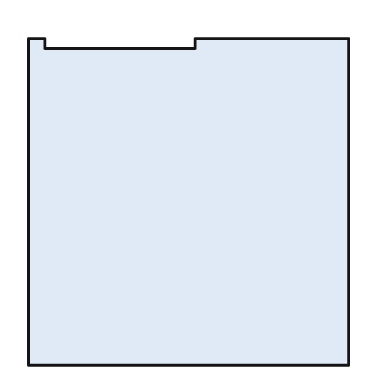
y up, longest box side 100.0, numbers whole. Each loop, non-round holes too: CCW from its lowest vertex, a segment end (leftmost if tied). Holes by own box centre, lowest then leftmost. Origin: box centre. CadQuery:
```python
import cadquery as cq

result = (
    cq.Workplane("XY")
    .moveTo(-49.0, -50.0)
    .lineTo(49.0, -50.0)
    .lineTo(49.0, 50.0)
    .lineTo(2.0, 50.0)
    .lineTo(2.0, 47.0)
    .lineTo(-44.0, 47.0)
    .lineTo(-44.0, 50.0)
    .lineTo(-49.0, 50.0)
    .close()
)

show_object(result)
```